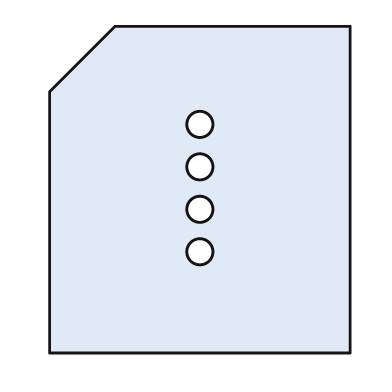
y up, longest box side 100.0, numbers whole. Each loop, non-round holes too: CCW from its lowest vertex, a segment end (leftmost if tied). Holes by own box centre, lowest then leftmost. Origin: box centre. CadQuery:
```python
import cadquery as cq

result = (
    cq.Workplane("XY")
    .moveTo(-46.0, -50.0)
    .lineTo(46.0, -50.0)
    .lineTo(46.0, 50.0)
    .lineTo(-26.0, 50.0)
    .lineTo(-46.0, 30.0)
    .close()
    .moveTo(0.0, -19.0)
    .circle(4.0)
    .moveTo(0.0, -6.0)
    .circle(4.0)
    .moveTo(0.0, 7.0)
    .circle(4.0)
    .moveTo(0.0, 20.0)
    .circle(4.0)
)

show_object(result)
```